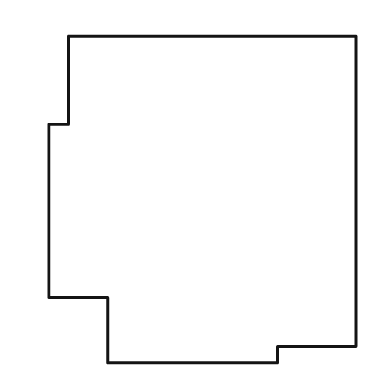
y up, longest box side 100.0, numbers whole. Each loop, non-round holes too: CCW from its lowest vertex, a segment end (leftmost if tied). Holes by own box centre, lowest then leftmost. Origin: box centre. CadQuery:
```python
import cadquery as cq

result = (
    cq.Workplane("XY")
    .moveTo(-29.0, -50.0)
    .lineTo(23.0, -50.0)
    .lineTo(23.0, -45.0)
    .lineTo(47.0, -45.0)
    .lineTo(47.0, 50.0)
    .lineTo(-41.0, 50.0)
    .lineTo(-41.0, 23.0)
    .lineTo(-47.0, 23.0)
    .lineTo(-47.0, -30.0)
    .lineTo(-29.0, -30.0)
    .close()
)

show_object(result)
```